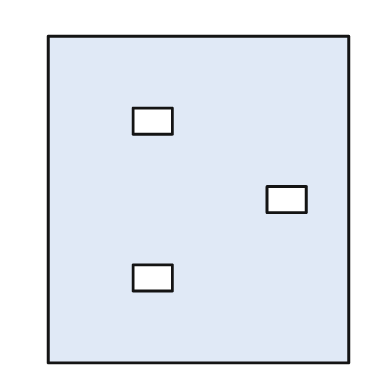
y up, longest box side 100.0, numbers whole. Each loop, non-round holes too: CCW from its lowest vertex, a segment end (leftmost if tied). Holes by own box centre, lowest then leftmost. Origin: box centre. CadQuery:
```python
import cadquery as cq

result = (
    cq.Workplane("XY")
    .moveTo(-46.0, -50.0)
    .lineTo(46.0, -50.0)
    .lineTo(46.0, 50.0)
    .lineTo(-46.0, 50.0)
    .close()
    .moveTo(-20.0, -28.0)
    .lineTo(-8.0, -28.0)
    .lineTo(-8.0, -20.0)
    .lineTo(-20.0, -20.0)
    .close()
    .moveTo(21.0, -4.0)
    .lineTo(33.0, -4.0)
    .lineTo(33.0, 4.0)
    .lineTo(21.0, 4.0)
    .close()
    .moveTo(-20.0, 20.0)
    .lineTo(-8.0, 20.0)
    .lineTo(-8.0, 28.0)
    .lineTo(-20.0, 28.0)
    .close()
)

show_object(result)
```